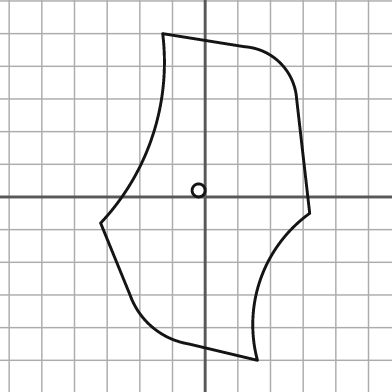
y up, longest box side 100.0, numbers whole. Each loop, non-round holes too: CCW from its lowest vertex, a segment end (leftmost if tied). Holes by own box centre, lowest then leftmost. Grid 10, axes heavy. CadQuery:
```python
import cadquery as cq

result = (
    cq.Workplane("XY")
    .moveTo(16.0, -50.0)
    .threePointArc((17.0, -25.0), (32.0, -5.0))
    .lineTo(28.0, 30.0)
    .threePointArc((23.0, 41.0), (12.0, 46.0))
    .lineTo(-13.0, 50.0)
    .threePointArc((-16.0, 19.0), (-32.0, -8.0))
    .lineTo(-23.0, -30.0)
    .threePointArc((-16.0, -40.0), (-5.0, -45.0))
    .close()
    .moveTo(-2.0, 2.0)
    .circle(2.0)
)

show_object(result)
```